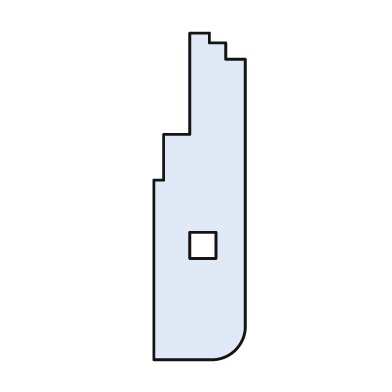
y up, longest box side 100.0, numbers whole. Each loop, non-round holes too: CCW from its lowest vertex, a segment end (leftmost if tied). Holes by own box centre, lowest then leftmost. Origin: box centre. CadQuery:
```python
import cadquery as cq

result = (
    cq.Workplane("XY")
    .moveTo(-14.0, -50.0)
    .lineTo(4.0, -50.0)
    .threePointArc((11.0, -47.0), (14.0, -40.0))
    .lineTo(14.0, 42.0)
    .lineTo(8.0, 42.0)
    .lineTo(8.0, 47.0)
    .lineTo(3.0, 47.0)
    .lineTo(3.0, 50.0)
    .lineTo(-3.0, 50.0)
    .lineTo(-3.0, 19.0)
    .lineTo(-11.0, 19.0)
    .lineTo(-11.0, 5.0)
    .lineTo(-14.0, 5.0)
    .close()
    .moveTo(-3.0, -19.0)
    .lineTo(5.0, -19.0)
    .lineTo(5.0, -11.0)
    .lineTo(-3.0, -11.0)
    .close()
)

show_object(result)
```